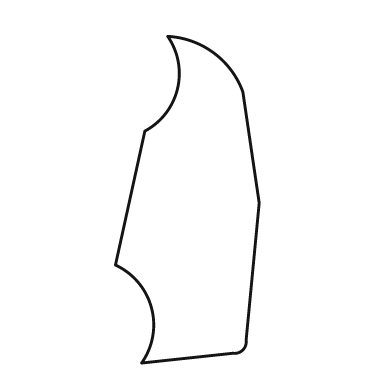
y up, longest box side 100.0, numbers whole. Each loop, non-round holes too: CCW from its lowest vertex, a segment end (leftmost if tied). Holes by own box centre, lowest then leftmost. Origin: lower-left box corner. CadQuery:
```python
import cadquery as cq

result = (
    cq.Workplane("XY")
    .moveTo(8.0, 0.0)
    .lineTo(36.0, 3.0)
    .threePointArc((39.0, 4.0), (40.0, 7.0))
    .lineTo(44.0, 49.0)
    .lineTo(39.0, 83.0)
    .threePointArc((30.0, 95.0), (16.0, 100.0))
    .threePointArc((19.0, 84.0), (9.0, 71.0))
    .lineTo(0.0, 30.0)
    .threePointArc((11.0, 17.0), (8.0, 0.0))
    .close()
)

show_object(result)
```